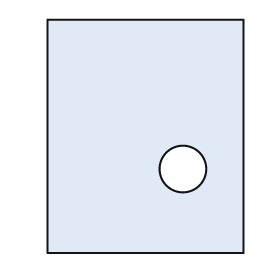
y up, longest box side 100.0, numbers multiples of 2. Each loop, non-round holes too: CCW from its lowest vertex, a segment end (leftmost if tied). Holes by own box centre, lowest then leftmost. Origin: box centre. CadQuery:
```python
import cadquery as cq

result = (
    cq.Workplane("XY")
    .moveTo(-42.0, -50.0)
    .lineTo(42.0, -50.0)
    .lineTo(42.0, 50.0)
    .lineTo(-42.0, 50.0)
    .close()
    .moveTo(16.0, -14.0)
    .circle(10.0)
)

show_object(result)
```